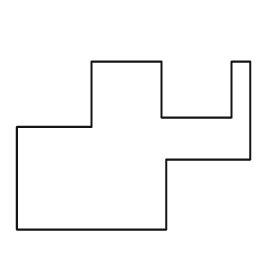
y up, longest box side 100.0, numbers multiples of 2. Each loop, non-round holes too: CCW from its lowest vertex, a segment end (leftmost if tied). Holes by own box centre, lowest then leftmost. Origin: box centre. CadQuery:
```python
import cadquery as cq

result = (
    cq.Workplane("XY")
    .moveTo(-50.0, -36.0)
    .lineTo(14.0, -36.0)
    .lineTo(14.0, -6.0)
    .lineTo(50.0, -6.0)
    .lineTo(50.0, 36.0)
    .lineTo(42.0, 36.0)
    .lineTo(42.0, 12.0)
    .lineTo(12.0, 12.0)
    .lineTo(12.0, 36.0)
    .lineTo(-18.0, 36.0)
    .lineTo(-18.0, 8.0)
    .lineTo(-50.0, 8.0)
    .close()
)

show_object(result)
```